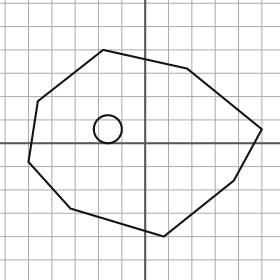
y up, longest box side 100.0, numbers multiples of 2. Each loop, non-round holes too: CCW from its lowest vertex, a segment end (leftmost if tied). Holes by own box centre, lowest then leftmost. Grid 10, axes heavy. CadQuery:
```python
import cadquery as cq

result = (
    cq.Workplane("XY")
    .moveTo(8.0, -40.0)
    .lineTo(38.0, -16.0)
    .lineTo(50.0, 6.0)
    .lineTo(18.0, 32.0)
    .lineTo(-18.0, 40.0)
    .lineTo(-46.0, 18.0)
    .lineTo(-50.0, -8.0)
    .lineTo(-32.0, -28.0)
    .close()
    .moveTo(-16.0, 6.0)
    .circle(6.0)
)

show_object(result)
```